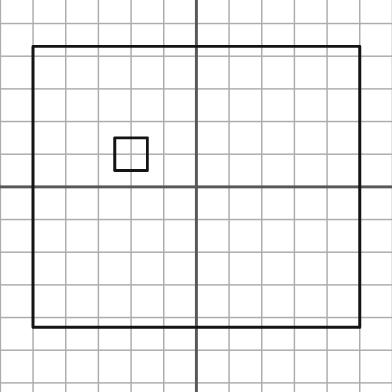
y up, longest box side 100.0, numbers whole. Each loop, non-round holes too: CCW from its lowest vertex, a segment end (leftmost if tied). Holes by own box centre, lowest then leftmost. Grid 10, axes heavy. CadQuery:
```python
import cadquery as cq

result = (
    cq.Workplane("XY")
    .moveTo(-50.0, -43.0)
    .lineTo(50.0, -43.0)
    .lineTo(50.0, 43.0)
    .lineTo(-50.0, 43.0)
    .close()
    .moveTo(-25.0, 5.0)
    .lineTo(-15.0, 5.0)
    .lineTo(-15.0, 15.0)
    .lineTo(-25.0, 15.0)
    .close()
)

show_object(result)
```